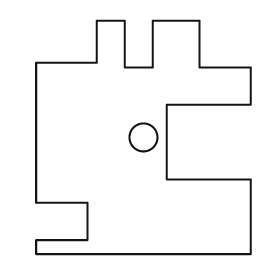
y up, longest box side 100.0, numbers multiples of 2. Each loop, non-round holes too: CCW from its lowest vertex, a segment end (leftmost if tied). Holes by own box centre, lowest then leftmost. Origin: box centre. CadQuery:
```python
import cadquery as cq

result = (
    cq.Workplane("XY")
    .moveTo(-46.0, -50.0)
    .lineTo(46.0, -50.0)
    .lineTo(46.0, -18.0)
    .lineTo(10.0, -18.0)
    .lineTo(10.0, 14.0)
    .lineTo(46.0, 14.0)
    .lineTo(46.0, 30.0)
    .lineTo(24.0, 30.0)
    .lineTo(24.0, 50.0)
    .lineTo(4.0, 50.0)
    .lineTo(4.0, 30.0)
    .lineTo(-8.0, 30.0)
    .lineTo(-8.0, 50.0)
    .lineTo(-20.0, 50.0)
    .lineTo(-20.0, 32.0)
    .lineTo(-46.0, 32.0)
    .lineTo(-46.0, -28.0)
    .lineTo(-24.0, -28.0)
    .lineTo(-24.0, -44.0)
    .lineTo(-46.0, -44.0)
    .close()
    .moveTo(0.0, 0.0)
    .circle(6.0)
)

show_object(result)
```